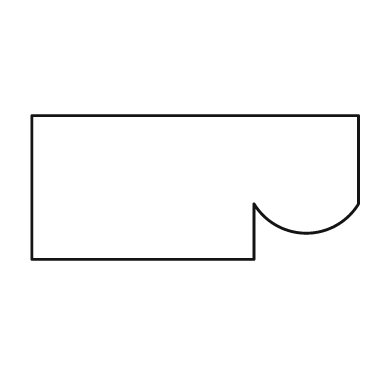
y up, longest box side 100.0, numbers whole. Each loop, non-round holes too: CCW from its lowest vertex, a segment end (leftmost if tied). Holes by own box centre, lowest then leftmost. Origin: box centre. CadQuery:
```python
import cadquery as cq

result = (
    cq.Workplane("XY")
    .moveTo(-50.0, -22.0)
    .lineTo(18.0, -22.0)
    .lineTo(18.0, -5.0)
    .threePointArc((34.0, -14.0), (50.0, -5.0))
    .lineTo(50.0, 22.0)
    .lineTo(-50.0, 22.0)
    .close()
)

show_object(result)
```